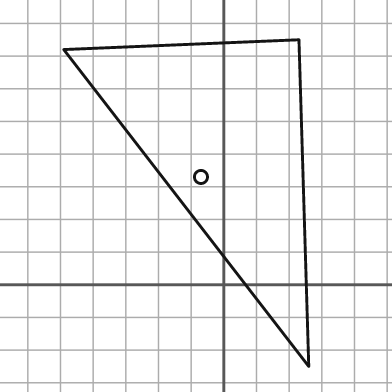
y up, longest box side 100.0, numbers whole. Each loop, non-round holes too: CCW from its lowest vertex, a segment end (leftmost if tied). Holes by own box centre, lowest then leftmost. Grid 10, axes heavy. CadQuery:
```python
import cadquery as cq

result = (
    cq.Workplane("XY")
    .moveTo(26.0, -25.0)
    .lineTo(23.0, 75.0)
    .lineTo(-49.0, 72.0)
    .close()
    .moveTo(-7.0, 33.0)
    .circle(2.0)
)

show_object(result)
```